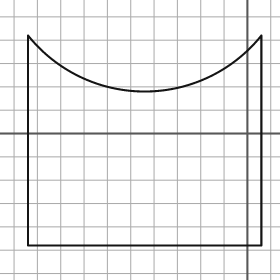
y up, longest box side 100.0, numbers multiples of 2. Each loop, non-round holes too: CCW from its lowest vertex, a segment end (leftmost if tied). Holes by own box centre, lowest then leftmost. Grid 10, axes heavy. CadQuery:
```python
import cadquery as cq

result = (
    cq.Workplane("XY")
    .moveTo(-94.0, -48.0)
    .lineTo(6.0, -48.0)
    .lineTo(6.0, 42.0)
    .threePointArc((-44.0, 18.0), (-94.0, 42.0))
    .close()
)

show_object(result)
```